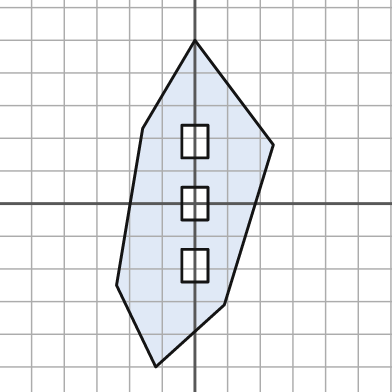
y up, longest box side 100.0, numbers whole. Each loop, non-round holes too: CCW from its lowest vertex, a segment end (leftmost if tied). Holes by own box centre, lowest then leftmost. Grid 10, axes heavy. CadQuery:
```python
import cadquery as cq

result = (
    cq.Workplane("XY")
    .moveTo(-12.0, -50.0)
    .lineTo(9.0, -31.0)
    .lineTo(24.0, 18.0)
    .lineTo(0.0, 50.0)
    .lineTo(-16.0, 23.0)
    .lineTo(-24.0, -25.0)
    .close()
    .moveTo(-4.0, -24.0)
    .lineTo(4.0, -24.0)
    .lineTo(4.0, -14.0)
    .lineTo(-4.0, -14.0)
    .close()
    .moveTo(-4.0, -5.0)
    .lineTo(4.0, -5.0)
    .lineTo(4.0, 5.0)
    .lineTo(-4.0, 5.0)
    .close()
    .moveTo(-4.0, 14.0)
    .lineTo(4.0, 14.0)
    .lineTo(4.0, 24.0)
    .lineTo(-4.0, 24.0)
    .close()
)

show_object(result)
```